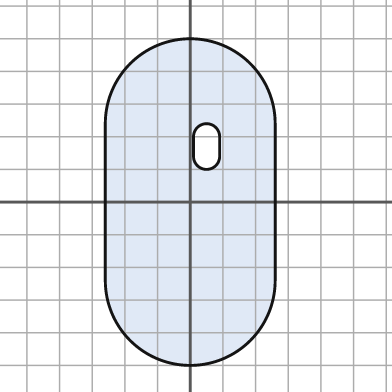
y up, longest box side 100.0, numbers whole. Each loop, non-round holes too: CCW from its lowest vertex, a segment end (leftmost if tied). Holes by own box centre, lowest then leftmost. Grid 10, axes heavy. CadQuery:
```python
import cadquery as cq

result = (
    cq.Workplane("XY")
    .moveTo(-26.0, -24.0)
    .threePointArc((0.0, -50.0), (26.0, -24.0))
    .lineTo(26.0, 24.0)
    .threePointArc((0.0, 50.0), (-26.0, 24.0))
    .close()
    .moveTo(1.0, 14.0)
    .threePointArc((5.0, 10.0), (9.0, 14.0))
    .lineTo(9.0, 20.0)
    .threePointArc((5.0, 24.0), (1.0, 20.0))
    .close()
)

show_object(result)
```